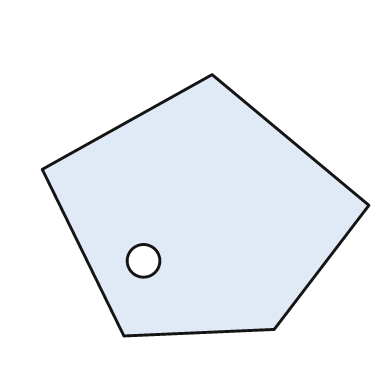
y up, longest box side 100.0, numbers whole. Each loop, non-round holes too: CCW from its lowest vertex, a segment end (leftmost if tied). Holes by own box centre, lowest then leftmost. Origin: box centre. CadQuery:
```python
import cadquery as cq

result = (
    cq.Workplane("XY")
    .moveTo(-25.0, -40.0)
    .lineTo(21.0, -38.0)
    .lineTo(50.0, 0.0)
    .lineTo(2.0, 40.0)
    .lineTo(-50.0, 11.0)
    .close()
    .moveTo(-19.0, -17.0)
    .circle(5.0)
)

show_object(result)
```